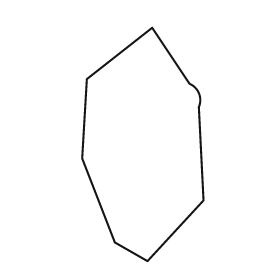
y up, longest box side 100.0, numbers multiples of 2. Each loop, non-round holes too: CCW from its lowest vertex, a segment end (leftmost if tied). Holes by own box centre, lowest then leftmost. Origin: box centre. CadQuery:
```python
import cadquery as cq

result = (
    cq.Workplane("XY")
    .moveTo(2.0, -50.0)
    .lineTo(26.0, -24.0)
    .lineTo(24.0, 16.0)
    .threePointArc((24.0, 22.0), (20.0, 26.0))
    .lineTo(4.0, 50.0)
    .lineTo(-24.0, 28.0)
    .lineTo(-26.0, -6.0)
    .lineTo(-12.0, -42.0)
    .close()
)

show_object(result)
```